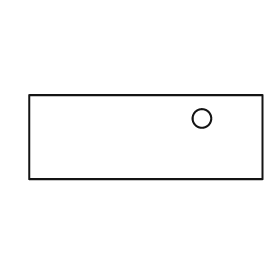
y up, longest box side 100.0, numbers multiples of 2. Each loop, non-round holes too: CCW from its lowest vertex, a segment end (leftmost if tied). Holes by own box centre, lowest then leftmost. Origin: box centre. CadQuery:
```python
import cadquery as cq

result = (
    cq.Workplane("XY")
    .moveTo(-50.0, -18.0)
    .lineTo(50.0, -18.0)
    .lineTo(50.0, 18.0)
    .lineTo(-50.0, 18.0)
    .close()
    .moveTo(24.0, 8.0)
    .circle(4.0)
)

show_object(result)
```